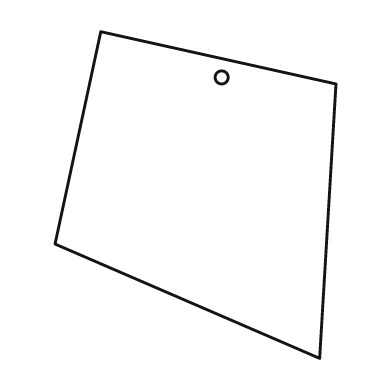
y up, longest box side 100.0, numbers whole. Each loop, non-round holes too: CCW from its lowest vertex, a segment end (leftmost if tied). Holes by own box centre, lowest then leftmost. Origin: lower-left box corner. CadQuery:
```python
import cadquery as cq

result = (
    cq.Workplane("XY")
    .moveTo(81.0, 0.0)
    .lineTo(86.0, 84.0)
    .lineTo(14.0, 100.0)
    .lineTo(0.0, 35.0)
    .close()
    .moveTo(51.0, 86.0)
    .circle(2.0)
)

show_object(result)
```